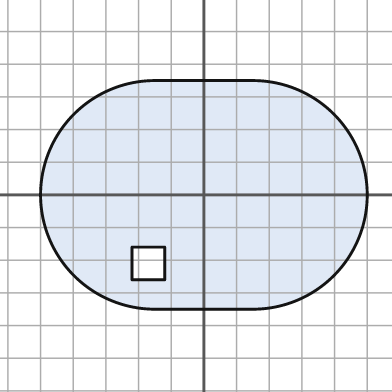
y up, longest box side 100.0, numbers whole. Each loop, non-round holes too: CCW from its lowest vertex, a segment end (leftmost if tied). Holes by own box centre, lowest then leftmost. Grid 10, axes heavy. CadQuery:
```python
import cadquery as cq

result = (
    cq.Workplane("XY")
    .moveTo(-15.0, -35.0)
    .lineTo(15.0, -35.0)
    .threePointArc((50.0, 0.0), (15.0, 35.0))
    .lineTo(-15.0, 35.0)
    .threePointArc((-50.0, 0.0), (-15.0, -35.0))
    .close()
    .moveTo(-22.0, -26.0)
    .lineTo(-12.0, -26.0)
    .lineTo(-12.0, -16.0)
    .lineTo(-22.0, -16.0)
    .close()
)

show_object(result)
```